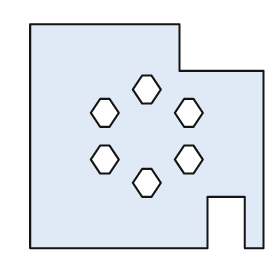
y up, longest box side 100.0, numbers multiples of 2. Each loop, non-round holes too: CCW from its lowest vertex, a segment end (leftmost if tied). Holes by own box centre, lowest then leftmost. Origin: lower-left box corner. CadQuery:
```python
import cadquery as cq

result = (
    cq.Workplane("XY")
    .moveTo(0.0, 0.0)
    .lineTo(76.0, 0.0)
    .lineTo(76.0, 22.0)
    .lineTo(92.0, 22.0)
    .lineTo(92.0, 0.0)
    .lineTo(100.0, 0.0)
    .lineTo(100.0, 76.0)
    .lineTo(64.0, 76.0)
    .lineTo(64.0, 96.0)
    .lineTo(0.0, 96.0)
    .close()
    .moveTo(48.0, 22.0)
    .lineTo(52.0, 22.0)
    .lineTo(56.0, 28.0)
    .lineTo(52.0, 34.0)
    .lineTo(48.0, 34.0)
    .lineTo(44.0, 28.0)
    .close()
    .moveTo(30.0, 32.0)
    .lineTo(34.0, 32.0)
    .lineTo(38.0, 38.0)
    .lineTo(34.0, 44.0)
    .lineTo(30.0, 44.0)
    .lineTo(26.0, 38.0)
    .close()
    .moveTo(66.0, 32.0)
    .lineTo(70.0, 32.0)
    .lineTo(74.0, 38.0)
    .lineTo(70.0, 44.0)
    .lineTo(66.0, 44.0)
    .lineTo(62.0, 38.0)
    .close()
    .moveTo(30.0, 52.0)
    .lineTo(34.0, 52.0)
    .lineTo(38.0, 58.0)
    .lineTo(34.0, 64.0)
    .lineTo(30.0, 64.0)
    .lineTo(26.0, 58.0)
    .close()
    .moveTo(66.0, 52.0)
    .lineTo(70.0, 52.0)
    .lineTo(74.0, 58.0)
    .lineTo(70.0, 64.0)
    .lineTo(66.0, 64.0)
    .lineTo(62.0, 58.0)
    .close()
    .moveTo(48.0, 62.0)
    .lineTo(52.0, 62.0)
    .lineTo(56.0, 68.0)
    .lineTo(52.0, 74.0)
    .lineTo(48.0, 74.0)
    .lineTo(44.0, 68.0)
    .close()
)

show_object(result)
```